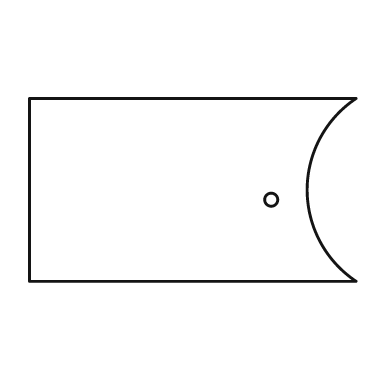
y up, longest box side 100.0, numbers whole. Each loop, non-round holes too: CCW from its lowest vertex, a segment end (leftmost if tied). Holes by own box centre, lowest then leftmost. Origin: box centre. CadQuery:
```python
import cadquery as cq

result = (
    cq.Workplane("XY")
    .moveTo(-50.0, -28.0)
    .lineTo(50.0, -28.0)
    .threePointArc((35.0, 0.0), (50.0, 28.0))
    .lineTo(-50.0, 28.0)
    .close()
    .moveTo(24.0, -3.0)
    .circle(2.0)
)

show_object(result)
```